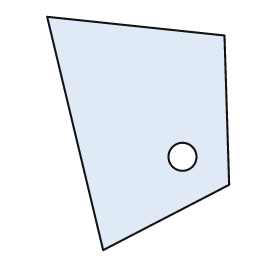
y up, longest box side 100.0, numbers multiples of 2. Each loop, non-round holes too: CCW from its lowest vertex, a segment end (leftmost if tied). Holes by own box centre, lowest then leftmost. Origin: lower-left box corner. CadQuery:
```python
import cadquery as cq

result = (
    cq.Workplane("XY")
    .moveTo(24.0, 0.0)
    .lineTo(78.0, 28.0)
    .lineTo(76.0, 92.0)
    .lineTo(0.0, 100.0)
    .close()
    .moveTo(58.0, 40.0)
    .circle(6.0)
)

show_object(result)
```